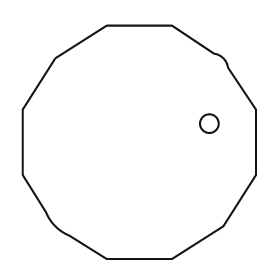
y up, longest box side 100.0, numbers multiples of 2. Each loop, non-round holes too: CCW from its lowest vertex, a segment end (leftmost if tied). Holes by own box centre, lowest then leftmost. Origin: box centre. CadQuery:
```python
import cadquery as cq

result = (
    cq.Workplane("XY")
    .moveTo(-14.0, -50.0)
    .lineTo(14.0, -50.0)
    .lineTo(36.0, -36.0)
    .lineTo(50.0, -14.0)
    .lineTo(50.0, 14.0)
    .lineTo(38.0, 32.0)
    .threePointArc((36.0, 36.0), (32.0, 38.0))
    .lineTo(14.0, 50.0)
    .lineTo(-14.0, 50.0)
    .lineTo(-36.0, 36.0)
    .lineTo(-50.0, 14.0)
    .lineTo(-50.0, -14.0)
    .lineTo(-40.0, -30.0)
    .threePointArc((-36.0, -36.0), (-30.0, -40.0))
    .close()
    .moveTo(30.0, 8.0)
    .circle(4.0)
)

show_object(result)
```